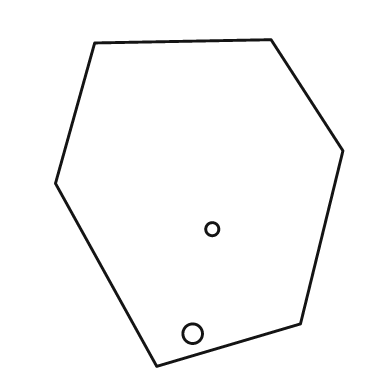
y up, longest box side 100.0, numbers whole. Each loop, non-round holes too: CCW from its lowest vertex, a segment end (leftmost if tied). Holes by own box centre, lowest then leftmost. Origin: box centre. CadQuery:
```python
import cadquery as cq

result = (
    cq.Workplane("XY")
    .moveTo(-13.0, -50.0)
    .lineTo(31.0, -37.0)
    .lineTo(44.0, 16.0)
    .lineTo(22.0, 50.0)
    .lineTo(-32.0, 49.0)
    .lineTo(-44.0, 6.0)
    .close()
    .moveTo(-2.0, -40.0)
    .circle(3.0)
    .moveTo(4.0, -8.0)
    .circle(2.0)
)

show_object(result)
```